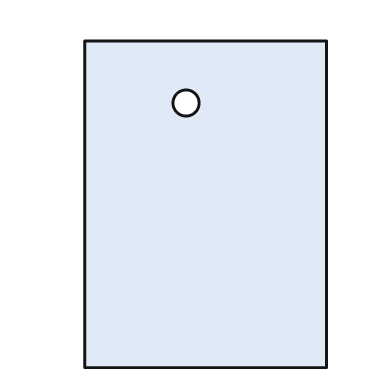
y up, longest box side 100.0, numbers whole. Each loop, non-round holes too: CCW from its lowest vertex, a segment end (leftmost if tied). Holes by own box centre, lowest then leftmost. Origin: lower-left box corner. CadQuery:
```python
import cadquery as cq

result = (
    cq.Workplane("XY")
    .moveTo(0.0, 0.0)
    .lineTo(74.0, 0.0)
    .lineTo(74.0, 100.0)
    .lineTo(0.0, 100.0)
    .close()
    .moveTo(31.0, 81.0)
    .circle(4.0)
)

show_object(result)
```